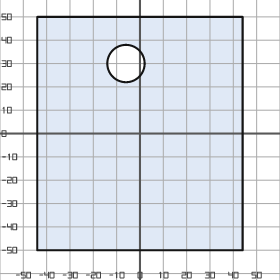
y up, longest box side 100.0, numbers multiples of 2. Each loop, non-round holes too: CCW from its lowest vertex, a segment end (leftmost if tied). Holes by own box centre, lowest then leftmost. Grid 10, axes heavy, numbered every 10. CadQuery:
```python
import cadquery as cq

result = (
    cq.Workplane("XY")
    .moveTo(-44.0, -50.0)
    .lineTo(44.0, -50.0)
    .lineTo(44.0, 50.0)
    .lineTo(-44.0, 50.0)
    .close()
    .moveTo(-6.0, 30.0)
    .circle(8.0)
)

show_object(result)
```